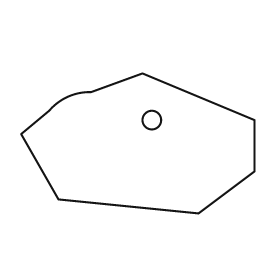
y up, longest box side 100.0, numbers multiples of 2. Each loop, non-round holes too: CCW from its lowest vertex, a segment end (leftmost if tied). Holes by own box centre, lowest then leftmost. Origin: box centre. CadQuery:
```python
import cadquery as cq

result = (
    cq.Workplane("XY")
    .moveTo(26.0, -30.0)
    .lineTo(50.0, -12.0)
    .lineTo(50.0, 10.0)
    .lineTo(2.0, 30.0)
    .lineTo(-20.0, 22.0)
    .threePointArc((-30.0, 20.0), (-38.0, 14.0))
    .lineTo(-50.0, 4.0)
    .lineTo(-34.0, -24.0)
    .close()
    .moveTo(6.0, 10.0)
    .circle(4.0)
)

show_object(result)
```